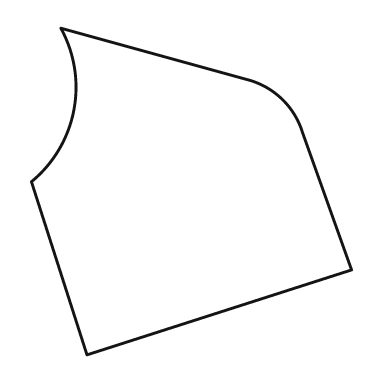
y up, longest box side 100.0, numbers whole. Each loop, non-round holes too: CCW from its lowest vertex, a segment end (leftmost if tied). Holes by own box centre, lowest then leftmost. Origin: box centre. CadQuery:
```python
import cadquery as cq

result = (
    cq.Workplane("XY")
    .moveTo(-32.0, -50.0)
    .lineTo(49.0, -24.0)
    .lineTo(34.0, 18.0)
    .threePointArc((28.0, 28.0), (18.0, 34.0))
    .lineTo(-40.0, 50.0)
    .threePointArc((-36.0, 25.0), (-49.0, 3.0))
    .close()
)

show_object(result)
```